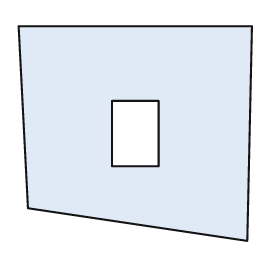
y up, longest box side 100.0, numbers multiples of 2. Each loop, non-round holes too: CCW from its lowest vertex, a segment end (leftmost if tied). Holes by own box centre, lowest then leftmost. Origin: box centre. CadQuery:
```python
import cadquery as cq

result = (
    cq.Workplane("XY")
    .moveTo(48.0, -46.0)
    .lineTo(50.0, 46.0)
    .lineTo(-50.0, 46.0)
    .lineTo(-46.0, -32.0)
    .close()
    .moveTo(-10.0, -14.0)
    .lineTo(10.0, -14.0)
    .lineTo(10.0, 14.0)
    .lineTo(-10.0, 14.0)
    .close()
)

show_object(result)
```